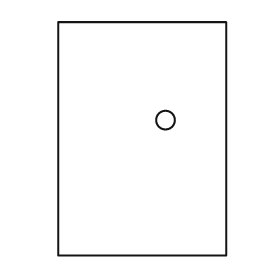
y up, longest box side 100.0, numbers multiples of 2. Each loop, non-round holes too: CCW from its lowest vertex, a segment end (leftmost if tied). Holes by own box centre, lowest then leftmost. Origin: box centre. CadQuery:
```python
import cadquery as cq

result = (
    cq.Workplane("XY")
    .moveTo(-36.0, -50.0)
    .lineTo(36.0, -50.0)
    .lineTo(36.0, 50.0)
    .lineTo(-36.0, 50.0)
    .close()
    .moveTo(10.0, 8.0)
    .circle(4.0)
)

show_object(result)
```